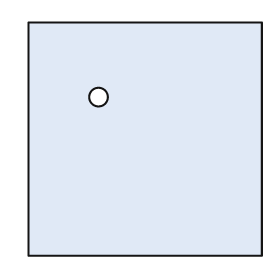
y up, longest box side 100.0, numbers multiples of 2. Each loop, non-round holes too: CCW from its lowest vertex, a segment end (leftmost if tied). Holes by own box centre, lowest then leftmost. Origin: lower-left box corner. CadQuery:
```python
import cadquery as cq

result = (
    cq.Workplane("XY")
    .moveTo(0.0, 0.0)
    .lineTo(100.0, 0.0)
    .lineTo(100.0, 100.0)
    .lineTo(0.0, 100.0)
    .close()
    .moveTo(30.0, 68.0)
    .circle(4.0)
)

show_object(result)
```